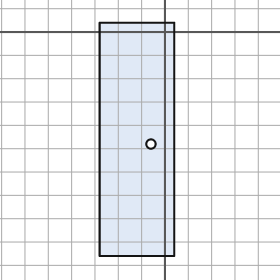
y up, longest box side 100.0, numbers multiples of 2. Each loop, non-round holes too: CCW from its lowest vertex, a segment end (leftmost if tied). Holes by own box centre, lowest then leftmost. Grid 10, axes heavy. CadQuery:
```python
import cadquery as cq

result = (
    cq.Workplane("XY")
    .moveTo(-28.0, -96.0)
    .lineTo(4.0, -96.0)
    .lineTo(4.0, 4.0)
    .lineTo(-28.0, 4.0)
    .close()
    .moveTo(-6.0, -48.0)
    .circle(2.0)
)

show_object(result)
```